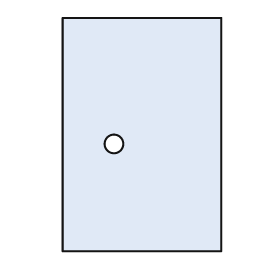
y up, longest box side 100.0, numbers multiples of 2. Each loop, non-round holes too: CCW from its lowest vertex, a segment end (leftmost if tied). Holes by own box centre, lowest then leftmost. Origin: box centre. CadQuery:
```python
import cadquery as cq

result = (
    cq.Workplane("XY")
    .moveTo(-34.0, -50.0)
    .lineTo(34.0, -50.0)
    .lineTo(34.0, 50.0)
    .lineTo(-34.0, 50.0)
    .close()
    .moveTo(-12.0, -4.0)
    .circle(4.0)
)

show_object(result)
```